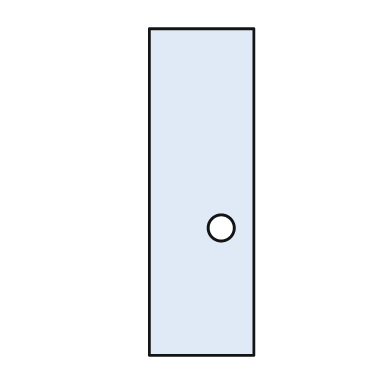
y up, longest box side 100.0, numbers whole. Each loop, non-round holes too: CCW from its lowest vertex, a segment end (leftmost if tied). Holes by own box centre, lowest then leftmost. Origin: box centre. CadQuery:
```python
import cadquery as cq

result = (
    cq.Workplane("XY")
    .moveTo(-16.0, -50.0)
    .lineTo(16.0, -50.0)
    .lineTo(16.0, 50.0)
    .lineTo(-16.0, 50.0)
    .close()
    .moveTo(6.0, -11.0)
    .circle(4.0)
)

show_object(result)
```